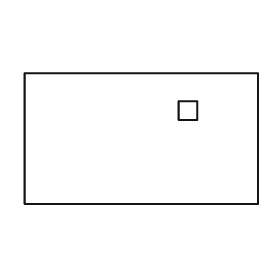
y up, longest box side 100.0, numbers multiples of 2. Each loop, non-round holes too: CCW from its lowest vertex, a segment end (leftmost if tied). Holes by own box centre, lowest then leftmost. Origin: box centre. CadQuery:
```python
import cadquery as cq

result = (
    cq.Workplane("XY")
    .moveTo(-50.0, -28.0)
    .lineTo(50.0, -28.0)
    .lineTo(50.0, 28.0)
    .lineTo(-50.0, 28.0)
    .close()
    .moveTo(16.0, 8.0)
    .lineTo(24.0, 8.0)
    .lineTo(24.0, 16.0)
    .lineTo(16.0, 16.0)
    .close()
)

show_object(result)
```